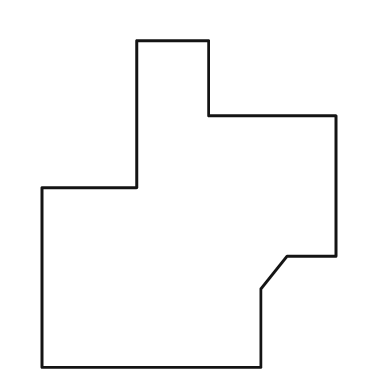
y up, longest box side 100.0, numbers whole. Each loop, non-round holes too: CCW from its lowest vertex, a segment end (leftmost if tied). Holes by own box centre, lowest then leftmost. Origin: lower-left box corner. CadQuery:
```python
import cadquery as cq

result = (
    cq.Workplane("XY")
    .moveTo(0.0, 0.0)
    .lineTo(67.0, 0.0)
    .lineTo(67.0, 24.0)
    .lineTo(75.0, 34.0)
    .lineTo(90.0, 34.0)
    .lineTo(90.0, 77.0)
    .lineTo(51.0, 77.0)
    .lineTo(51.0, 100.0)
    .lineTo(29.0, 100.0)
    .lineTo(29.0, 55.0)
    .lineTo(0.0, 55.0)
    .close()
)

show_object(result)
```